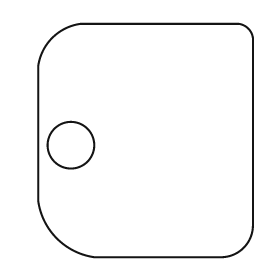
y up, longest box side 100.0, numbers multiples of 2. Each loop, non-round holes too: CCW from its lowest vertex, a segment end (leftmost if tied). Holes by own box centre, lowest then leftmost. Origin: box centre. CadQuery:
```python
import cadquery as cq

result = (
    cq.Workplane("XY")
    .moveTo(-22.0, -50.0)
    .lineTo(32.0, -50.0)
    .threePointArc((42.0, -46.0), (46.0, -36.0))
    .lineTo(46.0, 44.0)
    .threePointArc((44.0, 48.0), (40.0, 50.0))
    .lineTo(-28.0, 50.0)
    .threePointArc((-40.0, 44.0), (-46.0, 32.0))
    .lineTo(-46.0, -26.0)
    .threePointArc((-38.0, -42.0), (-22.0, -50.0))
    .close()
    .moveTo(-32.0, -2.0)
    .circle(10.0)
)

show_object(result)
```